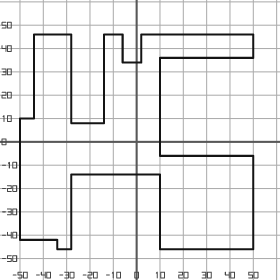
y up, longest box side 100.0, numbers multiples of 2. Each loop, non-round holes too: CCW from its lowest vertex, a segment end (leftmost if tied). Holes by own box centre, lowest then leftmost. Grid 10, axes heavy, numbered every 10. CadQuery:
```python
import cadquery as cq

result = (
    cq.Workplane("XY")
    .moveTo(-34.0, -46.0)
    .lineTo(-28.0, -46.0)
    .lineTo(-28.0, -14.0)
    .lineTo(10.0, -14.0)
    .lineTo(10.0, -46.0)
    .lineTo(50.0, -46.0)
    .lineTo(50.0, -6.0)
    .lineTo(10.0, -6.0)
    .lineTo(10.0, 36.0)
    .lineTo(50.0, 36.0)
    .lineTo(50.0, 46.0)
    .lineTo(2.0, 46.0)
    .lineTo(2.0, 34.0)
    .lineTo(-6.0, 34.0)
    .lineTo(-6.0, 46.0)
    .lineTo(-14.0, 46.0)
    .lineTo(-14.0, 8.0)
    .lineTo(-28.0, 8.0)
    .lineTo(-28.0, 46.0)
    .lineTo(-44.0, 46.0)
    .lineTo(-44.0, 10.0)
    .lineTo(-50.0, 10.0)
    .lineTo(-50.0, -42.0)
    .lineTo(-34.0, -42.0)
    .close()
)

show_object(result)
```